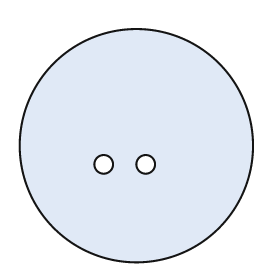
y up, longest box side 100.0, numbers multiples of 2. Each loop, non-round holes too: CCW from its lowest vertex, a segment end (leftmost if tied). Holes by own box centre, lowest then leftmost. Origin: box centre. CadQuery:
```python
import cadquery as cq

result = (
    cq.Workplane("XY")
    .moveTo(0.0, 0.0)
    .circle(50.0)
    .moveTo(-14.0, -8.0)
    .circle(4.0)
    .moveTo(4.0, -8.0)
    .circle(4.0)
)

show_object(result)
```